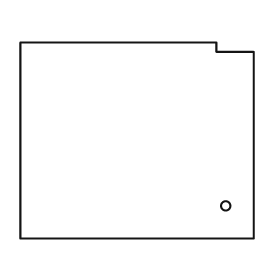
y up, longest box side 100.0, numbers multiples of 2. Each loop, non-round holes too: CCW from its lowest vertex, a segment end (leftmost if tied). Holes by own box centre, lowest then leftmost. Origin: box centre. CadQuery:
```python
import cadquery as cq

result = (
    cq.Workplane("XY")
    .moveTo(-50.0, -42.0)
    .lineTo(50.0, -42.0)
    .lineTo(50.0, 38.0)
    .lineTo(34.0, 38.0)
    .lineTo(34.0, 42.0)
    .lineTo(-50.0, 42.0)
    .close()
    .moveTo(38.0, -28.0)
    .circle(2.0)
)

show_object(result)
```